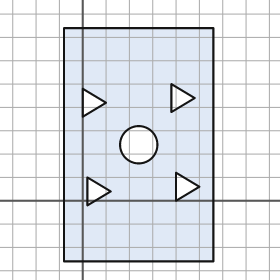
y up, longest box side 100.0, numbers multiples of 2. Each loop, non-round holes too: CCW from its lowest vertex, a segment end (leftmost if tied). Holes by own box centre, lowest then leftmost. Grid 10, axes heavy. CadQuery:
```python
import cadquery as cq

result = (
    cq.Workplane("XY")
    .moveTo(-8.0, -26.0)
    .lineTo(56.0, -26.0)
    .lineTo(56.0, 74.0)
    .lineTo(-8.0, 74.0)
    .close()
    .moveTo(2.0, -2.0)
    .lineTo(12.0, 4.0)
    .lineTo(2.0, 10.0)
    .close()
    .moveTo(40.0, 0.0)
    .lineTo(50.0, 6.0)
    .lineTo(40.0, 12.0)
    .close()
    .moveTo(24.0, 24.0)
    .circle(8.0)
    .moveTo(0.0, 36.0)
    .lineTo(10.0, 42.0)
    .lineTo(0.0, 48.0)
    .close()
    .moveTo(38.0, 38.0)
    .lineTo(48.0, 44.0)
    .lineTo(38.0, 50.0)
    .close()
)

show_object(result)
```